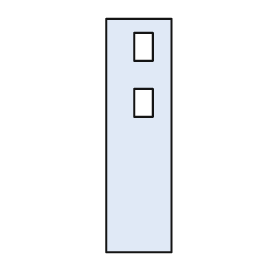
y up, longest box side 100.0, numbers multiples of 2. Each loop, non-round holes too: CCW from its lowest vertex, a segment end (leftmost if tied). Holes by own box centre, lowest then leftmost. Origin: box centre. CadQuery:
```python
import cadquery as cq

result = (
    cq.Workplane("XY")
    .moveTo(-14.0, -50.0)
    .lineTo(14.0, -50.0)
    .lineTo(14.0, 50.0)
    .lineTo(-14.0, 50.0)
    .close()
    .moveTo(-2.0, 8.0)
    .lineTo(6.0, 8.0)
    .lineTo(6.0, 20.0)
    .lineTo(-2.0, 20.0)
    .close()
    .moveTo(-2.0, 32.0)
    .lineTo(6.0, 32.0)
    .lineTo(6.0, 44.0)
    .lineTo(-2.0, 44.0)
    .close()
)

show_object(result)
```